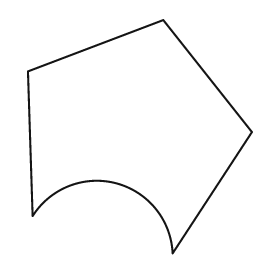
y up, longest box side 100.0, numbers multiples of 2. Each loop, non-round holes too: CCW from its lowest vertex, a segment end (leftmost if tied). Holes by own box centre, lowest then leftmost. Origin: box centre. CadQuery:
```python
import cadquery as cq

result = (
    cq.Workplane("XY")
    .moveTo(14.0, -50.0)
    .lineTo(48.0, 2.0)
    .lineTo(10.0, 50.0)
    .lineTo(-48.0, 28.0)
    .lineTo(-46.0, -34.0)
    .threePointArc((-10.0, -20.0), (14.0, -50.0))
    .close()
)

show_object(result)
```